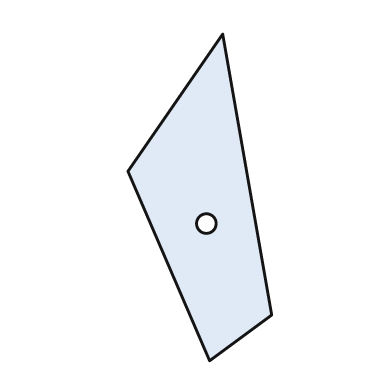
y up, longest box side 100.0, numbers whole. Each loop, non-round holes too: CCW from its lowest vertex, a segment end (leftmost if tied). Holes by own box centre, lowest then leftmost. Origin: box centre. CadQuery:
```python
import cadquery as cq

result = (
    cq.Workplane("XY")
    .moveTo(3.0, -50.0)
    .lineTo(22.0, -36.0)
    .lineTo(7.0, 50.0)
    .lineTo(-22.0, 8.0)
    .close()
    .moveTo(2.0, -8.0)
    .circle(3.0)
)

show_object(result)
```